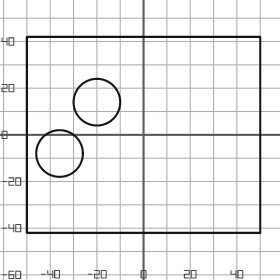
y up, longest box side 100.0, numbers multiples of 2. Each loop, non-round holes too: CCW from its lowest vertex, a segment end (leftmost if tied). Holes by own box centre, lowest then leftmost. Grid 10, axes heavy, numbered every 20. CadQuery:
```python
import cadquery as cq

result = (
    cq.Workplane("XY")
    .moveTo(-50.0, -42.0)
    .lineTo(50.0, -42.0)
    .lineTo(50.0, 42.0)
    .lineTo(-50.0, 42.0)
    .close()
    .moveTo(-36.0, -8.0)
    .circle(10.0)
    .moveTo(-20.0, 14.0)
    .circle(10.0)
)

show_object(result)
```